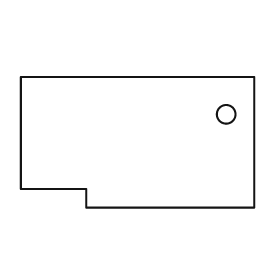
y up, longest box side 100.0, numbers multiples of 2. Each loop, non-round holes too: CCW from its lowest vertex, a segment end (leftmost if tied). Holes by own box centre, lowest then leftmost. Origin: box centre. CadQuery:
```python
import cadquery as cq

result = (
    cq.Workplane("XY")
    .moveTo(-22.0, -28.0)
    .lineTo(50.0, -28.0)
    .lineTo(50.0, 28.0)
    .lineTo(-50.0, 28.0)
    .lineTo(-50.0, -20.0)
    .lineTo(-22.0, -20.0)
    .close()
    .moveTo(38.0, 12.0)
    .circle(4.0)
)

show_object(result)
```